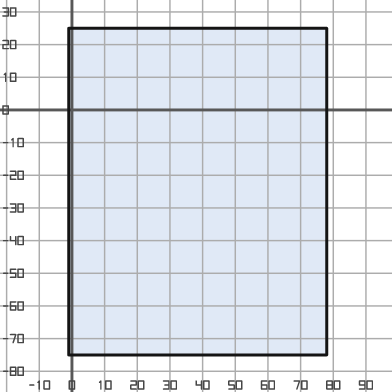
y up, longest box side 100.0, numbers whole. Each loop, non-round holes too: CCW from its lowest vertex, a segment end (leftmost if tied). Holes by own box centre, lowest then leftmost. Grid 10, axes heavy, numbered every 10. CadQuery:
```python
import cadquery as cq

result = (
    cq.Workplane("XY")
    .moveTo(-1.0, -75.0)
    .lineTo(78.0, -75.0)
    .lineTo(78.0, 25.0)
    .lineTo(-1.0, 25.0)
    .close()
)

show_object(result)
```